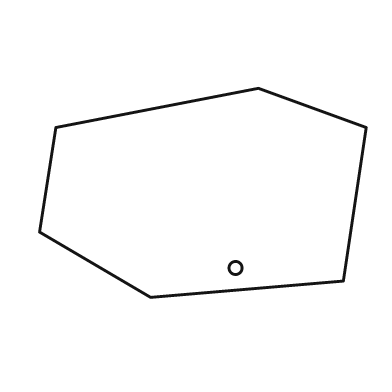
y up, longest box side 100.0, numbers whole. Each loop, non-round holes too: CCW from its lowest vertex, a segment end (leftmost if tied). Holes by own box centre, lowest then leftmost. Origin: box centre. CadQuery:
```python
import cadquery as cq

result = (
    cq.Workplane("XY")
    .moveTo(-16.0, -32.0)
    .lineTo(43.0, -27.0)
    .lineTo(50.0, 20.0)
    .lineTo(17.0, 32.0)
    .lineTo(-45.0, 20.0)
    .lineTo(-50.0, -12.0)
    .close()
    .moveTo(10.0, -23.0)
    .circle(2.0)
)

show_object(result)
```